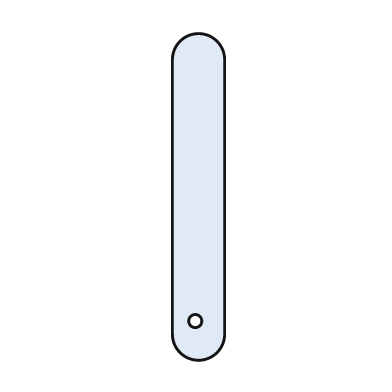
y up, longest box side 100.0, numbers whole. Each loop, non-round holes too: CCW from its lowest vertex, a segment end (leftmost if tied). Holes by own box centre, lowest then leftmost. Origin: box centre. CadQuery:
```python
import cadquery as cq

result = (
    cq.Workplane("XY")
    .moveTo(-8.0, -42.0)
    .threePointArc((0.0, -50.0), (8.0, -42.0))
    .lineTo(8.0, 42.0)
    .threePointArc((0.0, 50.0), (-8.0, 42.0))
    .close()
    .moveTo(-1.0, -38.0)
    .circle(2.0)
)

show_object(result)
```